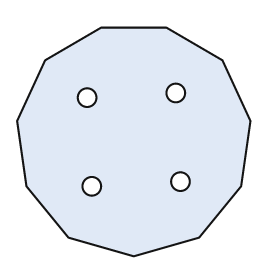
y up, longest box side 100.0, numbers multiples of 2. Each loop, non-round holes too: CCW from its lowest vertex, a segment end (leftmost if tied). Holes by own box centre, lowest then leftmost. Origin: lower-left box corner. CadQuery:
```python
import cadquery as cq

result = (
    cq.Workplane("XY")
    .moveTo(50.0, 0.0)
    .lineTo(78.0, 8.0)
    .lineTo(96.0, 30.0)
    .lineTo(100.0, 58.0)
    .lineTo(88.0, 84.0)
    .lineTo(64.0, 98.0)
    .lineTo(36.0, 98.0)
    .lineTo(12.0, 84.0)
    .lineTo(0.0, 58.0)
    .lineTo(4.0, 30.0)
    .lineTo(22.0, 8.0)
    .close()
    .moveTo(32.0, 30.0)
    .circle(4.0)
    .moveTo(70.0, 32.0)
    .circle(4.0)
    .moveTo(30.0, 68.0)
    .circle(4.0)
    .moveTo(68.0, 70.0)
    .circle(4.0)
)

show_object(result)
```